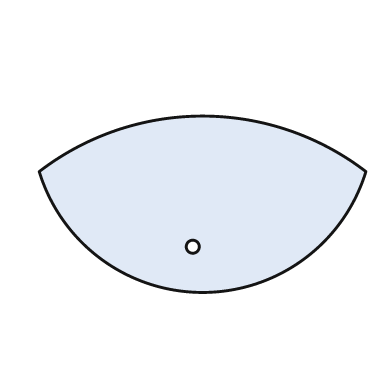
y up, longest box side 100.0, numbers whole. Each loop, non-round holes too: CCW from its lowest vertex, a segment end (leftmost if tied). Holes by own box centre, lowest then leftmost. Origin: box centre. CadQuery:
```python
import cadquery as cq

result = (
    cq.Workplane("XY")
    .moveTo(-50.0, 10.0)
    .threePointArc((0.0, -27.0), (50.0, 10.0))
    .threePointArc((0.0, 27.0), (-50.0, 10.0))
    .close()
    .moveTo(-3.0, -13.0)
    .circle(2.0)
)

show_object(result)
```